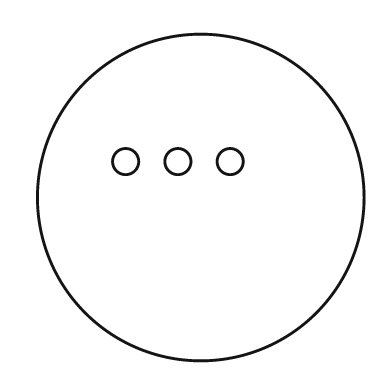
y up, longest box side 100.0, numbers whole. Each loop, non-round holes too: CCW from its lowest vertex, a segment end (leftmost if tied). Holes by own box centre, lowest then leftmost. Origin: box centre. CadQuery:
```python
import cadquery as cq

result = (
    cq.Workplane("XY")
    .moveTo(0.0, 0.0)
    .circle(50.0)
    .moveTo(-23.0, 11.0)
    .circle(4.0)
    .moveTo(-7.0, 11.0)
    .circle(4.0)
    .moveTo(9.0, 11.0)
    .circle(4.0)
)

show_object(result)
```